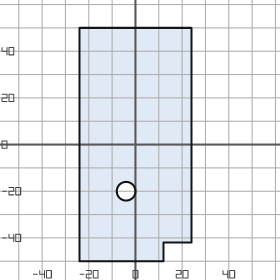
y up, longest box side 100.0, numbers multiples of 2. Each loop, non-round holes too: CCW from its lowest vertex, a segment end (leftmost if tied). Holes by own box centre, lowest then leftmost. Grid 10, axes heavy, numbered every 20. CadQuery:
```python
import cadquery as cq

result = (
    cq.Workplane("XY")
    .moveTo(-24.0, -50.0)
    .lineTo(12.0, -50.0)
    .lineTo(12.0, -42.0)
    .lineTo(24.0, -42.0)
    .lineTo(24.0, 50.0)
    .lineTo(-24.0, 50.0)
    .close()
    .moveTo(-4.0, -20.0)
    .circle(4.0)
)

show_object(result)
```